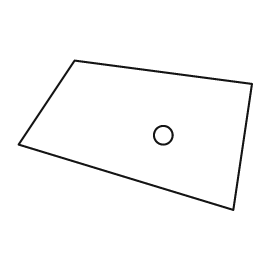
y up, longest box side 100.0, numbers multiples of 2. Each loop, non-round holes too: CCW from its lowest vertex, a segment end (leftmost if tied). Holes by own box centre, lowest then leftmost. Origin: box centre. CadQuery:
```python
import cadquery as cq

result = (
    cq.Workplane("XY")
    .moveTo(42.0, -32.0)
    .lineTo(50.0, 22.0)
    .lineTo(-26.0, 32.0)
    .lineTo(-50.0, -4.0)
    .close()
    .moveTo(12.0, 0.0)
    .circle(4.0)
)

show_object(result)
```